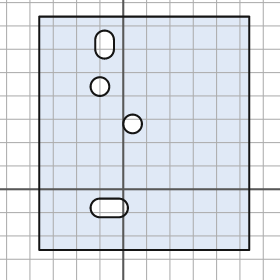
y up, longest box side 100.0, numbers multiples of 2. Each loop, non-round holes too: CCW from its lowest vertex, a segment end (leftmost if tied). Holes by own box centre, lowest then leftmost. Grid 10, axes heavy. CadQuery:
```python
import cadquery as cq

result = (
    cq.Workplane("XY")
    .moveTo(-36.0, -26.0)
    .lineTo(54.0, -26.0)
    .lineTo(54.0, 74.0)
    .lineTo(-36.0, 74.0)
    .close()
    .moveTo(-10.0, -12.0)
    .lineTo(-2.0, -12.0)
    .threePointArc((2.0, -8.0), (-2.0, -4.0))
    .lineTo(-10.0, -4.0)
    .threePointArc((-14.0, -8.0), (-10.0, -12.0))
    .close()
    .moveTo(4.0, 28.0)
    .circle(4.0)
    .moveTo(-10.0, 44.0)
    .circle(4.0)
    .moveTo(-12.0, 60.0)
    .threePointArc((-8.0, 56.0), (-4.0, 60.0))
    .lineTo(-4.0, 64.0)
    .threePointArc((-8.0, 68.0), (-12.0, 64.0))
    .close()
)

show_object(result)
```